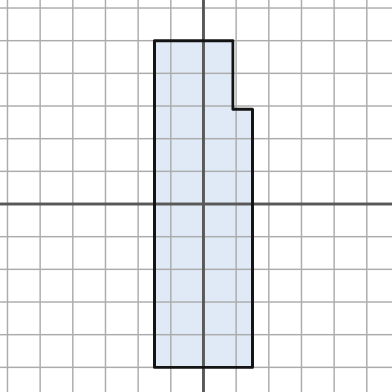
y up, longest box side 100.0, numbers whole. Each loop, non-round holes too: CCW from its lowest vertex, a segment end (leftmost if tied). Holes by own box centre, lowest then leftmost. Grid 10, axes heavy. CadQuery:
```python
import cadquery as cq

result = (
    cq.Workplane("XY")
    .moveTo(-15.0, -50.0)
    .lineTo(15.0, -50.0)
    .lineTo(15.0, 29.0)
    .lineTo(9.0, 29.0)
    .lineTo(9.0, 50.0)
    .lineTo(-15.0, 50.0)
    .close()
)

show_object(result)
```